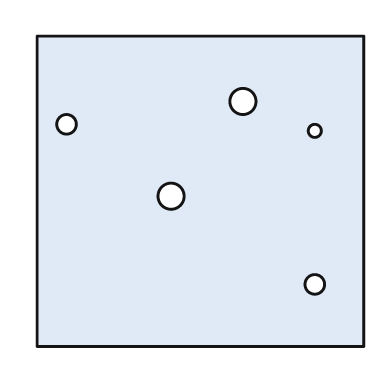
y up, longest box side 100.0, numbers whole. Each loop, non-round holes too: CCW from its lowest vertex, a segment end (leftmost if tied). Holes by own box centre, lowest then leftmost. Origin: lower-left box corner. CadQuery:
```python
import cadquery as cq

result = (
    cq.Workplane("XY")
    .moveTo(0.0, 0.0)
    .lineTo(100.0, 0.0)
    .lineTo(100.0, 95.0)
    .lineTo(0.0, 95.0)
    .close()
    .moveTo(85.0, 19.0)
    .circle(3.0)
    .moveTo(41.0, 46.0)
    .circle(4.0)
    .moveTo(85.0, 66.0)
    .circle(2.0)
    .moveTo(9.0, 68.0)
    .circle(3.0)
    .moveTo(63.0, 75.0)
    .circle(4.0)
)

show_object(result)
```